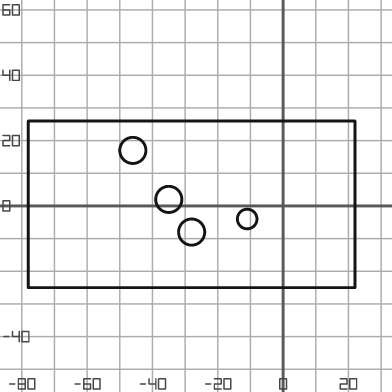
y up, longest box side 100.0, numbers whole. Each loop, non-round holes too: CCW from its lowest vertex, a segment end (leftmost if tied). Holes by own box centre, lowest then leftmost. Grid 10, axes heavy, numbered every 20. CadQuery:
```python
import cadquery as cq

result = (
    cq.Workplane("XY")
    .moveTo(-78.0, -25.0)
    .lineTo(22.0, -25.0)
    .lineTo(22.0, 26.0)
    .lineTo(-78.0, 26.0)
    .close()
    .moveTo(-28.0, -8.0)
    .circle(4.0)
    .moveTo(-11.0, -4.0)
    .circle(3.0)
    .moveTo(-35.0, 2.0)
    .circle(4.0)
    .moveTo(-46.0, 17.0)
    .circle(4.0)
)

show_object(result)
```